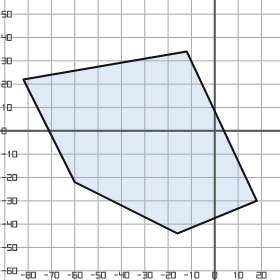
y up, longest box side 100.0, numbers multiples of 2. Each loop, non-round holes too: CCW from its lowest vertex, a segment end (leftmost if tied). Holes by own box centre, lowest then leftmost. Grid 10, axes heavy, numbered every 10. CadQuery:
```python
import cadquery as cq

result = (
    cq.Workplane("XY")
    .moveTo(-16.0, -44.0)
    .lineTo(18.0, -30.0)
    .lineTo(-12.0, 34.0)
    .lineTo(-82.0, 22.0)
    .lineTo(-60.0, -22.0)
    .close()
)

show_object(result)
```